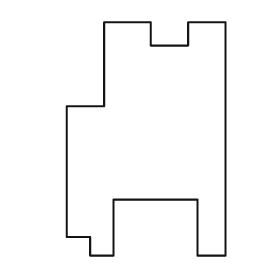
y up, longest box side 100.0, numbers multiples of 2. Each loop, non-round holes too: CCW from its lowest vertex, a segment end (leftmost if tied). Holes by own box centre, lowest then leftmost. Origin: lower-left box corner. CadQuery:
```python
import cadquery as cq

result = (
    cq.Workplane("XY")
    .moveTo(10.0, 0.0)
    .lineTo(20.0, 0.0)
    .lineTo(20.0, 24.0)
    .lineTo(56.0, 24.0)
    .lineTo(56.0, 0.0)
    .lineTo(68.0, 0.0)
    .lineTo(68.0, 100.0)
    .lineTo(52.0, 100.0)
    .lineTo(52.0, 90.0)
    .lineTo(36.0, 90.0)
    .lineTo(36.0, 100.0)
    .lineTo(16.0, 100.0)
    .lineTo(16.0, 64.0)
    .lineTo(0.0, 64.0)
    .lineTo(0.0, 8.0)
    .lineTo(10.0, 8.0)
    .close()
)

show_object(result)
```